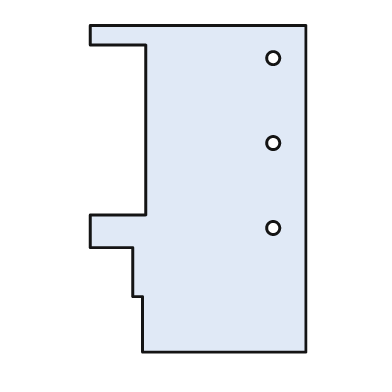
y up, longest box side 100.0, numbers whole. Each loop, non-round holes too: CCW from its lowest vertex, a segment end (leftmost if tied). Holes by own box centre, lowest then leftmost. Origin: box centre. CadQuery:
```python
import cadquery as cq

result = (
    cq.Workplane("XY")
    .moveTo(-17.0, -50.0)
    .lineTo(33.0, -50.0)
    .lineTo(33.0, 50.0)
    .lineTo(-33.0, 50.0)
    .lineTo(-33.0, 44.0)
    .lineTo(-16.0, 44.0)
    .lineTo(-16.0, -8.0)
    .lineTo(-33.0, -8.0)
    .lineTo(-33.0, -18.0)
    .lineTo(-20.0, -18.0)
    .lineTo(-20.0, -33.0)
    .lineTo(-17.0, -33.0)
    .close()
    .moveTo(23.0, -12.0)
    .circle(2.0)
    .moveTo(23.0, 14.0)
    .circle(2.0)
    .moveTo(23.0, 40.0)
    .circle(2.0)
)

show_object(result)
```